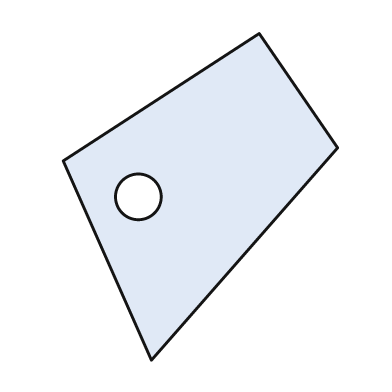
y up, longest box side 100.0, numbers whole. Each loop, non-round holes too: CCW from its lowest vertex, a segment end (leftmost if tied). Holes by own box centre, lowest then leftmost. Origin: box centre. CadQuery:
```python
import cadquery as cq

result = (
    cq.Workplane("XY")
    .moveTo(-15.0, -50.0)
    .lineTo(42.0, 15.0)
    .lineTo(18.0, 50.0)
    .lineTo(-42.0, 11.0)
    .close()
    .moveTo(-19.0, 0.0)
    .circle(7.0)
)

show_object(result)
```